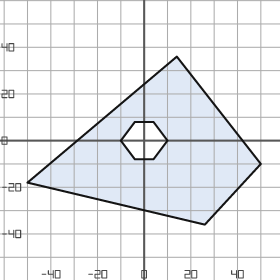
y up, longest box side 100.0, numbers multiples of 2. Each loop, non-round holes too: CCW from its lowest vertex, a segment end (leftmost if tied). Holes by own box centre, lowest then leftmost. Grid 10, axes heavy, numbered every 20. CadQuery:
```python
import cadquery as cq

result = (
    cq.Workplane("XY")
    .moveTo(26.0, -36.0)
    .lineTo(50.0, -10.0)
    .lineTo(14.0, 36.0)
    .lineTo(-50.0, -18.0)
    .close()
    .moveTo(-4.0, -8.0)
    .lineTo(4.0, -8.0)
    .lineTo(10.0, 0.0)
    .lineTo(4.0, 8.0)
    .lineTo(-4.0, 8.0)
    .lineTo(-10.0, 0.0)
    .close()
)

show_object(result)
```